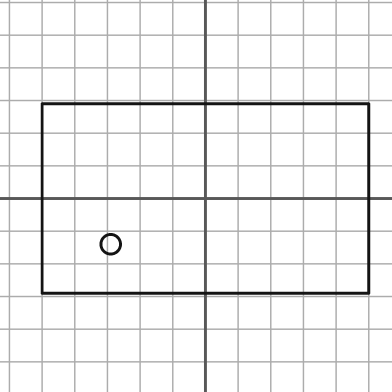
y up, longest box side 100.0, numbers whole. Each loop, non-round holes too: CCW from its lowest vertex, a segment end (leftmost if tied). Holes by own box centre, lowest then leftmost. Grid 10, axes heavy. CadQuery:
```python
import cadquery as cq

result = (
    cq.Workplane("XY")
    .moveTo(-50.0, -29.0)
    .lineTo(50.0, -29.0)
    .lineTo(50.0, 29.0)
    .lineTo(-50.0, 29.0)
    .close()
    .moveTo(-29.0, -14.0)
    .circle(3.0)
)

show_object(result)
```